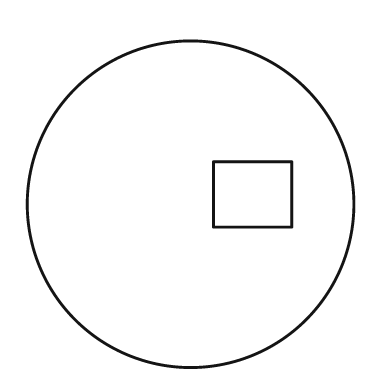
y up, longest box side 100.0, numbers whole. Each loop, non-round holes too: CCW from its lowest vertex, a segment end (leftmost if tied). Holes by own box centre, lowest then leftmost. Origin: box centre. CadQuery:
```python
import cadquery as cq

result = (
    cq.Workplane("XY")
    .moveTo(0.0, 0.0)
    .circle(50.0)
    .moveTo(7.0, -7.0)
    .lineTo(31.0, -7.0)
    .lineTo(31.0, 13.0)
    .lineTo(7.0, 13.0)
    .close()
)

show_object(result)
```